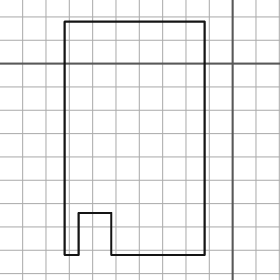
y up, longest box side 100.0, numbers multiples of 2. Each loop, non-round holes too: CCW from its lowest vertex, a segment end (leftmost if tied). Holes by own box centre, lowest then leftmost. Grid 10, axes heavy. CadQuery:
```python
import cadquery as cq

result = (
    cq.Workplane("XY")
    .moveTo(-72.0, -82.0)
    .lineTo(-66.0, -82.0)
    .lineTo(-66.0, -64.0)
    .lineTo(-52.0, -64.0)
    .lineTo(-52.0, -82.0)
    .lineTo(-12.0, -82.0)
    .lineTo(-12.0, 18.0)
    .lineTo(-72.0, 18.0)
    .close()
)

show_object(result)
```